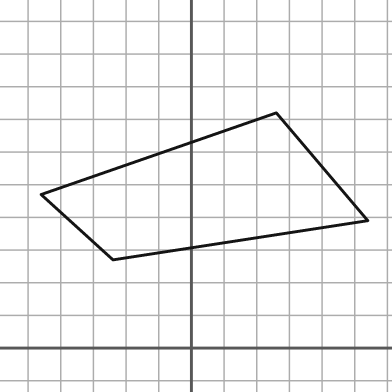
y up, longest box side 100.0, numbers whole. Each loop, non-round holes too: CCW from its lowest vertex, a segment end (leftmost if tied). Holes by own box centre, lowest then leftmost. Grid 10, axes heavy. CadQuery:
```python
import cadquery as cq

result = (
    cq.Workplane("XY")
    .moveTo(-24.0, 27.0)
    .lineTo(54.0, 39.0)
    .lineTo(26.0, 72.0)
    .lineTo(-46.0, 47.0)
    .close()
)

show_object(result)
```